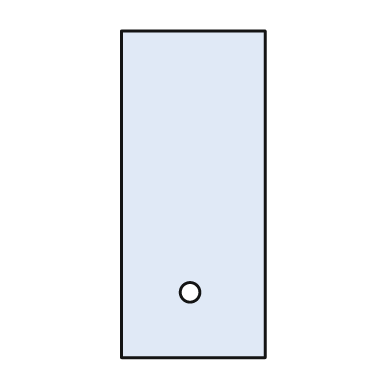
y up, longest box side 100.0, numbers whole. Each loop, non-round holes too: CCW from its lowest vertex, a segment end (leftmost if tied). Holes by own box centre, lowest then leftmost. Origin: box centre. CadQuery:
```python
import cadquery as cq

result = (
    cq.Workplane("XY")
    .moveTo(-22.0, -50.0)
    .lineTo(22.0, -50.0)
    .lineTo(22.0, 50.0)
    .lineTo(-22.0, 50.0)
    .close()
    .moveTo(-1.0, -30.0)
    .circle(3.0)
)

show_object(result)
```